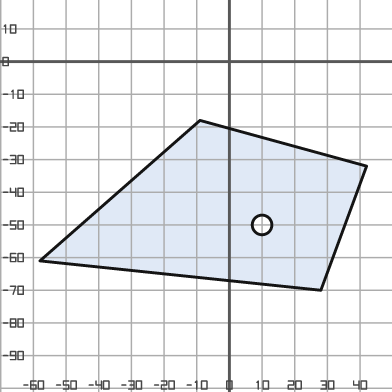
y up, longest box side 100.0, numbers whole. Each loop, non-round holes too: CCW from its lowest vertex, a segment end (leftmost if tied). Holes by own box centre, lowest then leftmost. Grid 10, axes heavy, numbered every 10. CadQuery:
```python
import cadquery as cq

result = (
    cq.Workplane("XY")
    .moveTo(28.0, -70.0)
    .lineTo(42.0, -32.0)
    .lineTo(-9.0, -18.0)
    .lineTo(-58.0, -61.0)
    .close()
    .moveTo(10.0, -50.0)
    .circle(3.0)
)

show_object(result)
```